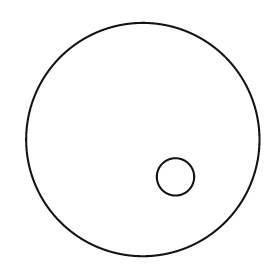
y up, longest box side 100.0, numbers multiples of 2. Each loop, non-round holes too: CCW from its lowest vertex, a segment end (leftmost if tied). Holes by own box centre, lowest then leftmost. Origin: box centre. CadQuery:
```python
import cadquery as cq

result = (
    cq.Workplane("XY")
    .moveTo(0.0, 0.0)
    .circle(50.0)
    .moveTo(14.0, -16.0)
    .circle(8.0)
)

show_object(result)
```